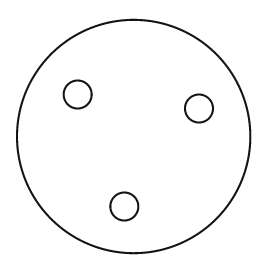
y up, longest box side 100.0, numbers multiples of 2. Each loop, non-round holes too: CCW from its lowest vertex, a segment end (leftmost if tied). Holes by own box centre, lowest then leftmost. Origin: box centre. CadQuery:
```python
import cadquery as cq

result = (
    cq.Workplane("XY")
    .moveTo(0.0, 0.0)
    .circle(50.0)
    .moveTo(-4.0, -30.0)
    .circle(6.0)
    .moveTo(28.0, 12.0)
    .circle(6.0)
    .moveTo(-24.0, 18.0)
    .circle(6.0)
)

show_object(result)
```